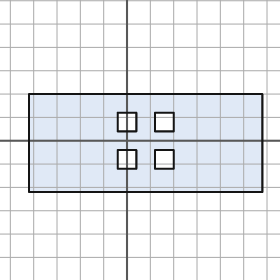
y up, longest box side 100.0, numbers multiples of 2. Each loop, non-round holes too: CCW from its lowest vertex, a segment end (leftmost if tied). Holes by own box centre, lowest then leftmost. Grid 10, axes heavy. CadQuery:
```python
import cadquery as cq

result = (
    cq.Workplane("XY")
    .moveTo(-42.0, -22.0)
    .lineTo(58.0, -22.0)
    .lineTo(58.0, 20.0)
    .lineTo(-42.0, 20.0)
    .close()
    .moveTo(-4.0, -12.0)
    .lineTo(4.0, -12.0)
    .lineTo(4.0, -4.0)
    .lineTo(-4.0, -4.0)
    .close()
    .moveTo(12.0, -12.0)
    .lineTo(20.0, -12.0)
    .lineTo(20.0, -4.0)
    .lineTo(12.0, -4.0)
    .close()
    .moveTo(-4.0, 4.0)
    .lineTo(4.0, 4.0)
    .lineTo(4.0, 12.0)
    .lineTo(-4.0, 12.0)
    .close()
    .moveTo(12.0, 4.0)
    .lineTo(20.0, 4.0)
    .lineTo(20.0, 12.0)
    .lineTo(12.0, 12.0)
    .close()
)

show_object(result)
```